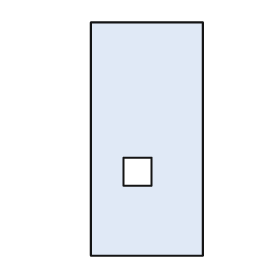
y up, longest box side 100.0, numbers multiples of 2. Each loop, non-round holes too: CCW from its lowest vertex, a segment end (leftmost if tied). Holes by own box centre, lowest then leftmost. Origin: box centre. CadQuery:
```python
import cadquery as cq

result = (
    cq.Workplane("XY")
    .moveTo(-24.0, -50.0)
    .lineTo(24.0, -50.0)
    .lineTo(24.0, 50.0)
    .lineTo(-24.0, 50.0)
    .close()
    .moveTo(-10.0, -20.0)
    .lineTo(2.0, -20.0)
    .lineTo(2.0, -8.0)
    .lineTo(-10.0, -8.0)
    .close()
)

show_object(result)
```